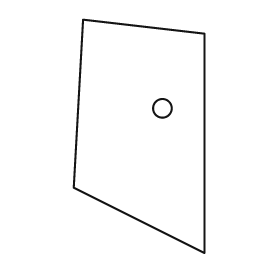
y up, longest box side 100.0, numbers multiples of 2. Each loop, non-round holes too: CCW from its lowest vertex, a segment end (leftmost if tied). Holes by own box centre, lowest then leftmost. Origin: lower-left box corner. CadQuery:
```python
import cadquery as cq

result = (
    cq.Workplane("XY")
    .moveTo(56.0, 0.0)
    .lineTo(56.0, 94.0)
    .lineTo(4.0, 100.0)
    .lineTo(0.0, 28.0)
    .close()
    .moveTo(38.0, 62.0)
    .circle(4.0)
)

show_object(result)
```